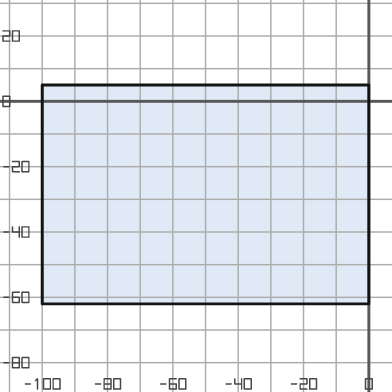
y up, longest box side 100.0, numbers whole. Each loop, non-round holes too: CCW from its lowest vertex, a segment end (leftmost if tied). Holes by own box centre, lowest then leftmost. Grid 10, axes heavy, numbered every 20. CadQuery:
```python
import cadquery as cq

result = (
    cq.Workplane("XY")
    .moveTo(-100.0, -62.0)
    .lineTo(0.0, -62.0)
    .lineTo(0.0, 5.0)
    .lineTo(-100.0, 5.0)
    .close()
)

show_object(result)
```